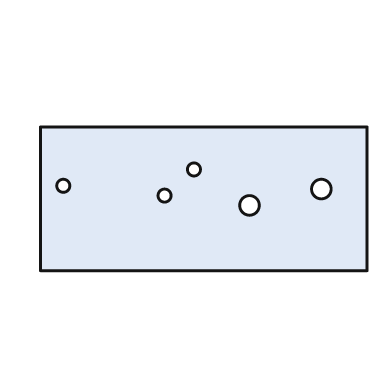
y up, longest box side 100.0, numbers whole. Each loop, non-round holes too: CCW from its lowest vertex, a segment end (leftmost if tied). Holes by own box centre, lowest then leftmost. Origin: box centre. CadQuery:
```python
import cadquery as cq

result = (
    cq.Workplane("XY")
    .moveTo(-50.0, -22.0)
    .lineTo(50.0, -22.0)
    .lineTo(50.0, 22.0)
    .lineTo(-50.0, 22.0)
    .close()
    .moveTo(14.0, -2.0)
    .circle(3.0)
    .moveTo(-12.0, 1.0)
    .circle(2.0)
    .moveTo(36.0, 3.0)
    .circle(3.0)
    .moveTo(-43.0, 4.0)
    .circle(2.0)
    .moveTo(-3.0, 9.0)
    .circle(2.0)
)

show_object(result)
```